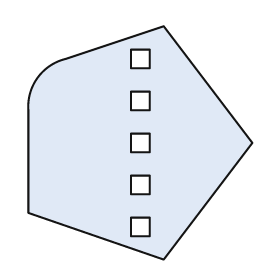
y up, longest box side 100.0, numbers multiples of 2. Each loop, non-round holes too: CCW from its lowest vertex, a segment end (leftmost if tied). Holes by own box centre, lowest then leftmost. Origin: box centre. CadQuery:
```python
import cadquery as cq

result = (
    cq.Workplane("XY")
    .moveTo(10.0, -50.0)
    .lineTo(48.0, 0.0)
    .lineTo(10.0, 50.0)
    .lineTo(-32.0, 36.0)
    .threePointArc((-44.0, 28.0), (-48.0, 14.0))
    .lineTo(-48.0, -30.0)
    .close()
    .moveTo(-4.0, -40.0)
    .lineTo(4.0, -40.0)
    .lineTo(4.0, -32.0)
    .lineTo(-4.0, -32.0)
    .close()
    .moveTo(-4.0, -22.0)
    .lineTo(4.0, -22.0)
    .lineTo(4.0, -14.0)
    .lineTo(-4.0, -14.0)
    .close()
    .moveTo(-4.0, -4.0)
    .lineTo(4.0, -4.0)
    .lineTo(4.0, 4.0)
    .lineTo(-4.0, 4.0)
    .close()
    .moveTo(-4.0, 14.0)
    .lineTo(4.0, 14.0)
    .lineTo(4.0, 22.0)
    .lineTo(-4.0, 22.0)
    .close()
    .moveTo(-4.0, 32.0)
    .lineTo(4.0, 32.0)
    .lineTo(4.0, 40.0)
    .lineTo(-4.0, 40.0)
    .close()
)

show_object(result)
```